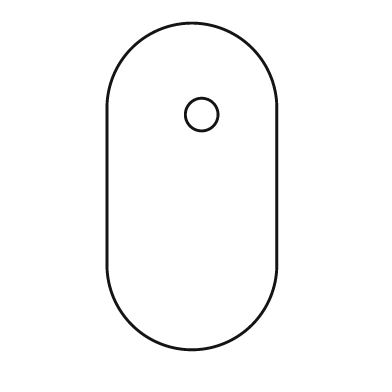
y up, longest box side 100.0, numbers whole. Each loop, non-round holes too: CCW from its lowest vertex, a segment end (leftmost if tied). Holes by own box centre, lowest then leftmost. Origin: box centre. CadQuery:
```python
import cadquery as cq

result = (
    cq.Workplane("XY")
    .moveTo(-26.0, -24.0)
    .threePointArc((0.0, -50.0), (26.0, -24.0))
    .lineTo(26.0, 24.0)
    .threePointArc((0.0, 50.0), (-26.0, 24.0))
    .close()
    .moveTo(3.0, 22.0)
    .circle(5.0)
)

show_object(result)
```